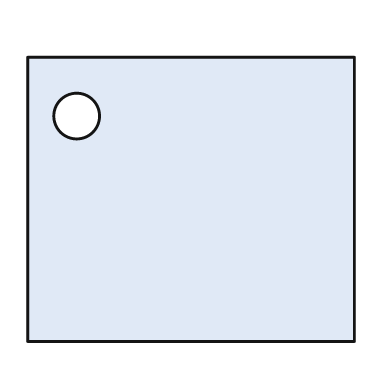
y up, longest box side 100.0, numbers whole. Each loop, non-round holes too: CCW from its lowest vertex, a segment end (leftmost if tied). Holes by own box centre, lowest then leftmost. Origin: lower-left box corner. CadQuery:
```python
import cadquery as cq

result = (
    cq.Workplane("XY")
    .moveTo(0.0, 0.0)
    .lineTo(100.0, 0.0)
    .lineTo(100.0, 87.0)
    .lineTo(0.0, 87.0)
    .close()
    .moveTo(15.0, 69.0)
    .circle(7.0)
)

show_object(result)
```